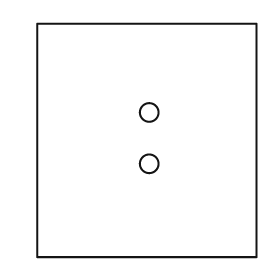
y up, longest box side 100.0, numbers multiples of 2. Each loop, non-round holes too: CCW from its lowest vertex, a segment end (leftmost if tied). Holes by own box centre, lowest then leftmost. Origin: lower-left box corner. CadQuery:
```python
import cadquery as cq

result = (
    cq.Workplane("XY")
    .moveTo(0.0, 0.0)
    .lineTo(94.0, 0.0)
    .lineTo(94.0, 100.0)
    .lineTo(0.0, 100.0)
    .close()
    .moveTo(48.0, 40.0)
    .circle(4.0)
    .moveTo(48.0, 62.0)
    .circle(4.0)
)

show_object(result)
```